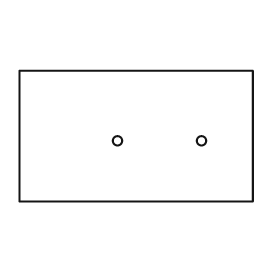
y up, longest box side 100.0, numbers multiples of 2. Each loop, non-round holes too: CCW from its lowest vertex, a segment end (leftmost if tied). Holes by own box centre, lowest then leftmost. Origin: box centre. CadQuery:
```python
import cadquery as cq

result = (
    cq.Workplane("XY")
    .moveTo(-50.0, -28.0)
    .lineTo(50.0, -28.0)
    .lineTo(50.0, 28.0)
    .lineTo(-50.0, 28.0)
    .close()
    .moveTo(-8.0, -2.0)
    .circle(2.0)
    .moveTo(28.0, -2.0)
    .circle(2.0)
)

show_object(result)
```